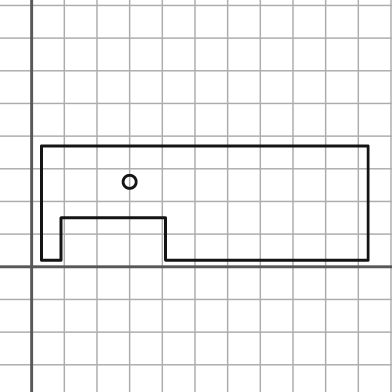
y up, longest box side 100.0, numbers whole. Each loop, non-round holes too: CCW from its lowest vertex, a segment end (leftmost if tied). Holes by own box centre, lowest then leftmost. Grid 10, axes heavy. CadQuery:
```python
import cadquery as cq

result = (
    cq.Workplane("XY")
    .moveTo(3.0, 2.0)
    .lineTo(9.0, 2.0)
    .lineTo(9.0, 15.0)
    .lineTo(41.0, 15.0)
    .lineTo(41.0, 2.0)
    .lineTo(103.0, 2.0)
    .lineTo(103.0, 37.0)
    .lineTo(3.0, 37.0)
    .close()
    .moveTo(30.0, 26.0)
    .circle(2.0)
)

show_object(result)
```